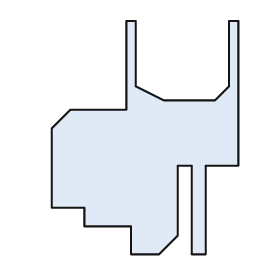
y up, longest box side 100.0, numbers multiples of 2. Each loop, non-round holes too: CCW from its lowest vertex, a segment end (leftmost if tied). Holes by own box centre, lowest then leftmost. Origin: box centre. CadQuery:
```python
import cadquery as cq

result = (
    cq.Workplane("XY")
    .moveTo(-6.0, -50.0)
    .lineTo(6.0, -50.0)
    .lineTo(14.0, -42.0)
    .lineTo(14.0, -12.0)
    .lineTo(20.0, -12.0)
    .lineTo(20.0, -50.0)
    .lineTo(26.0, -50.0)
    .lineTo(26.0, -12.0)
    .lineTo(40.0, -12.0)
    .lineTo(40.0, 50.0)
    .lineTo(36.0, 50.0)
    .lineTo(36.0, 22.0)
    .lineTo(30.0, 16.0)
    .lineTo(8.0, 16.0)
    .lineTo(-4.0, 22.0)
    .lineTo(-4.0, 50.0)
    .lineTo(-8.0, 50.0)
    .lineTo(-8.0, 12.0)
    .lineTo(-32.0, 12.0)
    .lineTo(-40.0, 4.0)
    .lineTo(-40.0, -30.0)
    .lineTo(-26.0, -30.0)
    .lineTo(-26.0, -38.0)
    .lineTo(-6.0, -38.0)
    .close()
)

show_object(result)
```